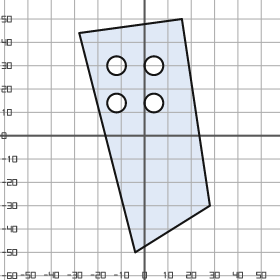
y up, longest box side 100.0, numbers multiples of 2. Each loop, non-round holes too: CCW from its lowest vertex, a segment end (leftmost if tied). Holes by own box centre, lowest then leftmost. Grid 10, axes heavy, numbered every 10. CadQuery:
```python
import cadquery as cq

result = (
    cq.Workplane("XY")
    .moveTo(-4.0, -50.0)
    .lineTo(28.0, -30.0)
    .lineTo(16.0, 50.0)
    .lineTo(-28.0, 44.0)
    .close()
    .moveTo(-12.0, 14.0)
    .circle(4.0)
    .moveTo(4.0, 14.0)
    .circle(4.0)
    .moveTo(-12.0, 30.0)
    .circle(4.0)
    .moveTo(4.0, 30.0)
    .circle(4.0)
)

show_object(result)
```